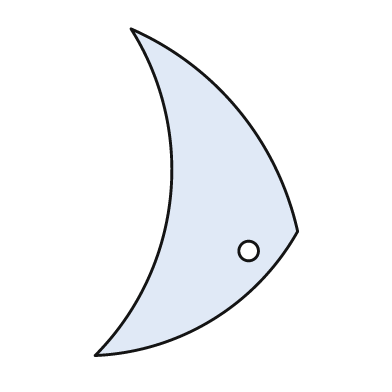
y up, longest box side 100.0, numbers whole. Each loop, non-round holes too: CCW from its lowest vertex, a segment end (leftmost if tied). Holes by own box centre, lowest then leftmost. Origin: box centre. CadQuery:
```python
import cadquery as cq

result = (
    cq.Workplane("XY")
    .moveTo(-31.0, -50.0)
    .threePointArc((5.0, -39.0), (31.0, -12.0))
    .threePointArc((13.0, 25.0), (-20.0, 50.0))
    .threePointArc((-8.0, -2.0), (-31.0, -50.0))
    .close()
    .moveTo(16.0, -18.0)
    .circle(3.0)
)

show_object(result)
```